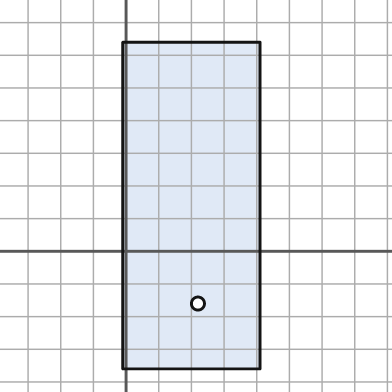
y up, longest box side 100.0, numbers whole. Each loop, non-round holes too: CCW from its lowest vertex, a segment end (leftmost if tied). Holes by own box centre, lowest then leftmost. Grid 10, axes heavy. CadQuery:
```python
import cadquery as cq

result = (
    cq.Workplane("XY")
    .moveTo(-1.0, -36.0)
    .lineTo(41.0, -36.0)
    .lineTo(41.0, 64.0)
    .lineTo(-1.0, 64.0)
    .close()
    .moveTo(22.0, -16.0)
    .circle(2.0)
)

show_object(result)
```